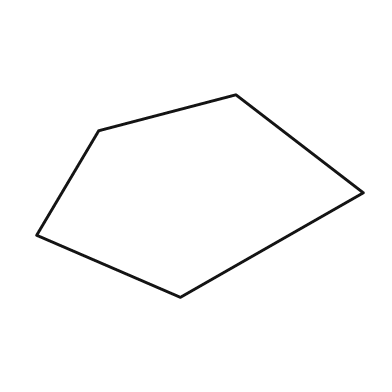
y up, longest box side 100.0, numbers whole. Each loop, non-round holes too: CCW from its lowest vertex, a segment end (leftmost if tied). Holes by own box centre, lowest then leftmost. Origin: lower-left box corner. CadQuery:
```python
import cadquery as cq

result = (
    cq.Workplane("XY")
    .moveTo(44.0, 0.0)
    .lineTo(100.0, 32.0)
    .lineTo(61.0, 62.0)
    .lineTo(19.0, 51.0)
    .lineTo(0.0, 19.0)
    .close()
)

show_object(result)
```